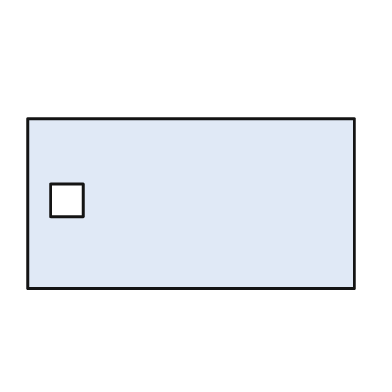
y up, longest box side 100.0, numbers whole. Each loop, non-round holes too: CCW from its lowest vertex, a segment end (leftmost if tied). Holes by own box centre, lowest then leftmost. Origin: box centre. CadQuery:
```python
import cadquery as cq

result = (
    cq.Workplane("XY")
    .moveTo(-50.0, -26.0)
    .lineTo(50.0, -26.0)
    .lineTo(50.0, 26.0)
    .lineTo(-50.0, 26.0)
    .close()
    .moveTo(-43.0, -4.0)
    .lineTo(-33.0, -4.0)
    .lineTo(-33.0, 6.0)
    .lineTo(-43.0, 6.0)
    .close()
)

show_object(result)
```